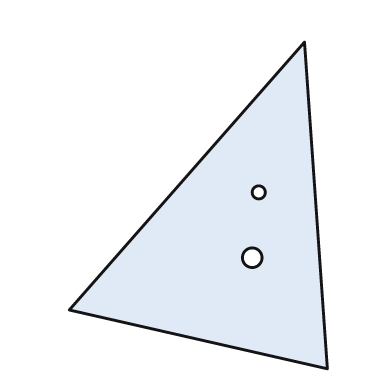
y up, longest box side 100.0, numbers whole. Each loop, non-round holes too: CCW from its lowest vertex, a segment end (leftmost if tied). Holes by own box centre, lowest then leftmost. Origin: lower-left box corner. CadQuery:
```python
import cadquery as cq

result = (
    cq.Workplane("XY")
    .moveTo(79.0, 0.0)
    .lineTo(72.0, 100.0)
    .lineTo(0.0, 18.0)
    .close()
    .moveTo(56.0, 34.0)
    .circle(3.0)
    .moveTo(58.0, 54.0)
    .circle(2.0)
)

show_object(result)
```